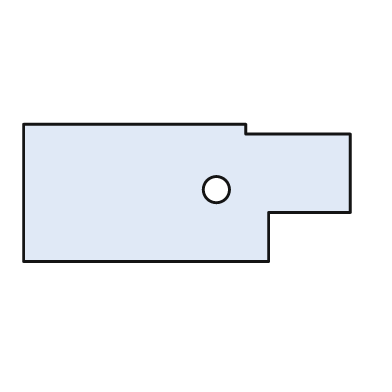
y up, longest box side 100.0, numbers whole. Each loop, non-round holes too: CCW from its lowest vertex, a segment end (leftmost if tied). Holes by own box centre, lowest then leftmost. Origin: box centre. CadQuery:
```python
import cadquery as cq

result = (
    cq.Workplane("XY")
    .moveTo(-50.0, -21.0)
    .lineTo(25.0, -21.0)
    .lineTo(25.0, -6.0)
    .lineTo(50.0, -6.0)
    .lineTo(50.0, 18.0)
    .lineTo(18.0, 18.0)
    .lineTo(18.0, 21.0)
    .lineTo(-50.0, 21.0)
    .close()
    .moveTo(9.0, 1.0)
    .circle(4.0)
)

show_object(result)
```